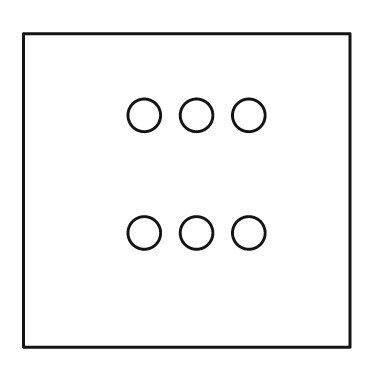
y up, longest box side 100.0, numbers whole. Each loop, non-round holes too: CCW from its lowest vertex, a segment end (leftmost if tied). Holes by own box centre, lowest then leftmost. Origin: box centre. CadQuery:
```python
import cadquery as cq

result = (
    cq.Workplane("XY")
    .moveTo(-50.0, -48.0)
    .lineTo(50.0, -48.0)
    .lineTo(50.0, 48.0)
    .lineTo(-50.0, 48.0)
    .close()
    .moveTo(-13.0, -13.0)
    .circle(5.0)
    .moveTo(3.0, -13.0)
    .circle(5.0)
    .moveTo(19.0, -13.0)
    .circle(5.0)
    .moveTo(-13.0, 23.0)
    .circle(5.0)
    .moveTo(3.0, 23.0)
    .circle(5.0)
    .moveTo(19.0, 23.0)
    .circle(5.0)
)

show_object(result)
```